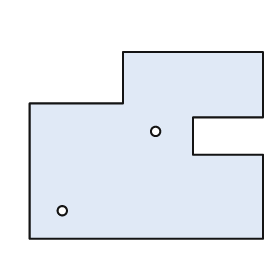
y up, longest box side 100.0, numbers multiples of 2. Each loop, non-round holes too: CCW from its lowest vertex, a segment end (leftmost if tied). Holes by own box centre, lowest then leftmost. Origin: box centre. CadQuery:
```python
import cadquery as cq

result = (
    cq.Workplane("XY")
    .moveTo(-50.0, -40.0)
    .lineTo(50.0, -40.0)
    .lineTo(50.0, -4.0)
    .lineTo(20.0, -4.0)
    .lineTo(20.0, 12.0)
    .lineTo(50.0, 12.0)
    .lineTo(50.0, 40.0)
    .lineTo(-10.0, 40.0)
    .lineTo(-10.0, 18.0)
    .lineTo(-50.0, 18.0)
    .close()
    .moveTo(-36.0, -28.0)
    .circle(2.0)
    .moveTo(4.0, 6.0)
    .circle(2.0)
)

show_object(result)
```